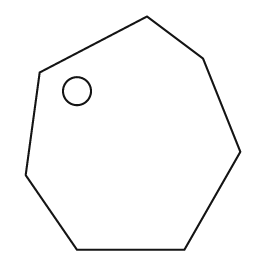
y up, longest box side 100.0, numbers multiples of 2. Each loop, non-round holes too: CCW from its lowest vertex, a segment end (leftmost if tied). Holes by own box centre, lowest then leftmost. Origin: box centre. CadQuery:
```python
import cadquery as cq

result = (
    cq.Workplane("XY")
    .moveTo(-24.0, -50.0)
    .lineTo(22.0, -50.0)
    .lineTo(46.0, -8.0)
    .lineTo(30.0, 32.0)
    .lineTo(6.0, 50.0)
    .lineTo(-40.0, 26.0)
    .lineTo(-46.0, -18.0)
    .close()
    .moveTo(-24.0, 18.0)
    .circle(6.0)
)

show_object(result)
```